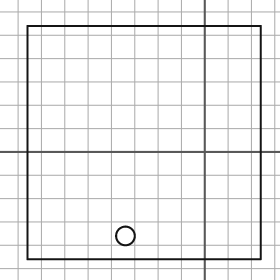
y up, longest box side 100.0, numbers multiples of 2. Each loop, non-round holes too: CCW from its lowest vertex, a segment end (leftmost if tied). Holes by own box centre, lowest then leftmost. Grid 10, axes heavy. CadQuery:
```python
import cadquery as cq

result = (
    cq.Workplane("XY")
    .moveTo(-76.0, -46.0)
    .lineTo(24.0, -46.0)
    .lineTo(24.0, 54.0)
    .lineTo(-76.0, 54.0)
    .close()
    .moveTo(-34.0, -36.0)
    .circle(4.0)
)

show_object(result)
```